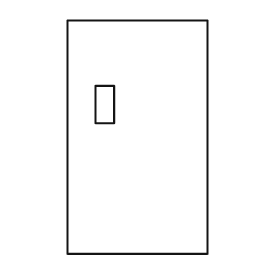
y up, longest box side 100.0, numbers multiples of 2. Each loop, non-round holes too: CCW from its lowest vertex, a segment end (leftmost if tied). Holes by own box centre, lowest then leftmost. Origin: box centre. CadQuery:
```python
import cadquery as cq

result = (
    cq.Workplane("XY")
    .moveTo(-30.0, -50.0)
    .lineTo(30.0, -50.0)
    .lineTo(30.0, 50.0)
    .lineTo(-30.0, 50.0)
    .close()
    .moveTo(-18.0, 6.0)
    .lineTo(-10.0, 6.0)
    .lineTo(-10.0, 22.0)
    .lineTo(-18.0, 22.0)
    .close()
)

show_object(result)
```